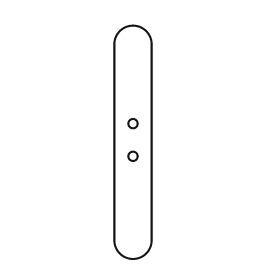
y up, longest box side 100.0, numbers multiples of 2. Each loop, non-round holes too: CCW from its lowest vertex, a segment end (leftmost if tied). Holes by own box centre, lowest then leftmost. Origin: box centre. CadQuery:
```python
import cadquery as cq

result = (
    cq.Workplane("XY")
    .moveTo(-8.0, -42.0)
    .threePointArc((0.0, -50.0), (8.0, -42.0))
    .lineTo(8.0, 42.0)
    .threePointArc((0.0, 50.0), (-8.0, 42.0))
    .close()
    .moveTo(0.0, -6.0)
    .circle(2.0)
    .moveTo(0.0, 8.0)
    .circle(2.0)
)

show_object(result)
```